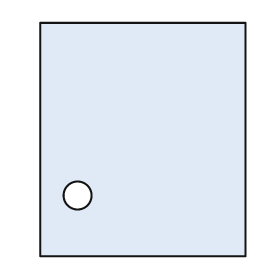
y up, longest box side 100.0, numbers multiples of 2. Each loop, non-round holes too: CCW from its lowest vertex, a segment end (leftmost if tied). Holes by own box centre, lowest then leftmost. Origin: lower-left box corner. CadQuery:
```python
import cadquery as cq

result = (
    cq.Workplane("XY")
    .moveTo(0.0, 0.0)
    .lineTo(88.0, 0.0)
    .lineTo(88.0, 100.0)
    .lineTo(0.0, 100.0)
    .close()
    .moveTo(16.0, 26.0)
    .circle(6.0)
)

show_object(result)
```